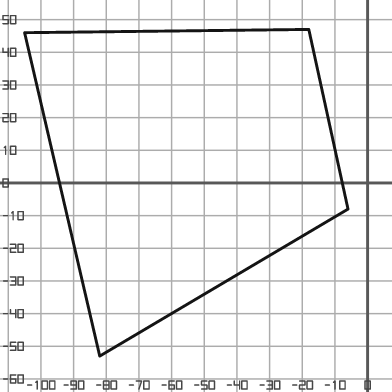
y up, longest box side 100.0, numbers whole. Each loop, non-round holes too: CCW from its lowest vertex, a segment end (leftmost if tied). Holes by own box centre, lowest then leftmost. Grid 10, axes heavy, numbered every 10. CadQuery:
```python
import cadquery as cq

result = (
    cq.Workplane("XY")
    .moveTo(-82.0, -53.0)
    .lineTo(-6.0, -8.0)
    .lineTo(-18.0, 47.0)
    .lineTo(-105.0, 46.0)
    .close()
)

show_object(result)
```